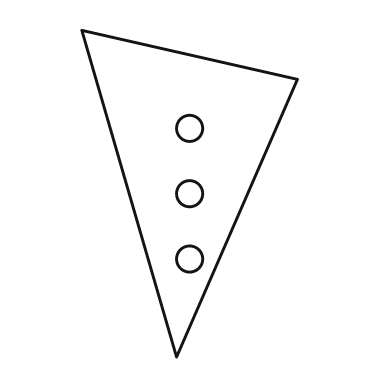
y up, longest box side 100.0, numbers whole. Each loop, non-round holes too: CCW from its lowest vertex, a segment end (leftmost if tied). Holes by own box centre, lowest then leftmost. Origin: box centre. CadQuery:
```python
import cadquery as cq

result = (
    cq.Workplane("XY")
    .moveTo(-4.0, -50.0)
    .lineTo(33.0, 35.0)
    .lineTo(-33.0, 50.0)
    .close()
    .moveTo(0.0, -20.0)
    .circle(4.0)
    .moveTo(0.0, 0.0)
    .circle(4.0)
    .moveTo(0.0, 20.0)
    .circle(4.0)
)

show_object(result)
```